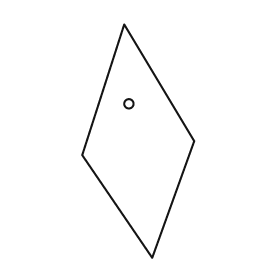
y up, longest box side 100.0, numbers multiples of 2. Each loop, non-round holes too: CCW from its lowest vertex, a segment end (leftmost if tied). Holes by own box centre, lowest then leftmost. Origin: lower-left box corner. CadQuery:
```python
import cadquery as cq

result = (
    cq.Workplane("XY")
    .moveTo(30.0, 0.0)
    .lineTo(48.0, 50.0)
    .lineTo(18.0, 100.0)
    .lineTo(0.0, 44.0)
    .close()
    .moveTo(20.0, 66.0)
    .circle(2.0)
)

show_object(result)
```